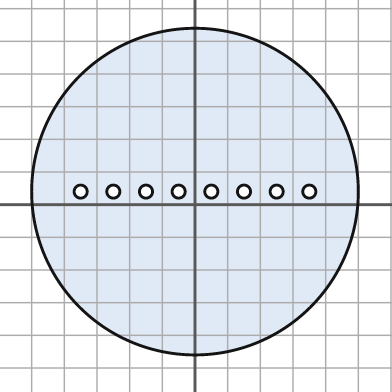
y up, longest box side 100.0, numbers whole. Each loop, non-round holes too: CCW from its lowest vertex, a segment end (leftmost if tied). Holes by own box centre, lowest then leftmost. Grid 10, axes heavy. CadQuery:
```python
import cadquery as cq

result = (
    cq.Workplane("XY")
    .moveTo(0.0, 4.0)
    .circle(50.0)
    .moveTo(-35.0, 4.0)
    .circle(2.0)
    .moveTo(-25.0, 4.0)
    .circle(2.0)
    .moveTo(-15.0, 4.0)
    .circle(2.0)
    .moveTo(-5.0, 4.0)
    .circle(2.0)
    .moveTo(5.0, 4.0)
    .circle(2.0)
    .moveTo(15.0, 4.0)
    .circle(2.0)
    .moveTo(25.0, 4.0)
    .circle(2.0)
    .moveTo(35.0, 4.0)
    .circle(2.0)
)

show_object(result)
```